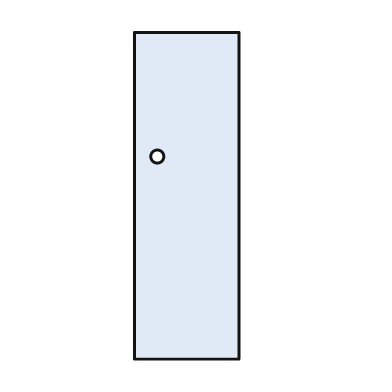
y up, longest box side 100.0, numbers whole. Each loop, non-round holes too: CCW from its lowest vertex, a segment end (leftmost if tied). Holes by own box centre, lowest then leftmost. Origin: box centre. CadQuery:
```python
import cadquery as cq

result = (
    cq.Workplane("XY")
    .moveTo(-16.0, -50.0)
    .lineTo(16.0, -50.0)
    .lineTo(16.0, 50.0)
    .lineTo(-16.0, 50.0)
    .close()
    .moveTo(-9.0, 12.0)
    .circle(2.0)
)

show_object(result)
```